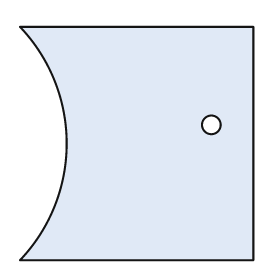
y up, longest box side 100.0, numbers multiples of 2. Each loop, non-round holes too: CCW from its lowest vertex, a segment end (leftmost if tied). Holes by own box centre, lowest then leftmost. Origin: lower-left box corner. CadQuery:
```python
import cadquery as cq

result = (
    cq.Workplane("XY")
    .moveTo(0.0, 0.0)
    .lineTo(100.0, 0.0)
    .lineTo(100.0, 100.0)
    .lineTo(0.0, 100.0)
    .threePointArc((20.0, 50.0), (0.0, 0.0))
    .close()
    .moveTo(82.0, 58.0)
    .circle(4.0)
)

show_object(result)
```